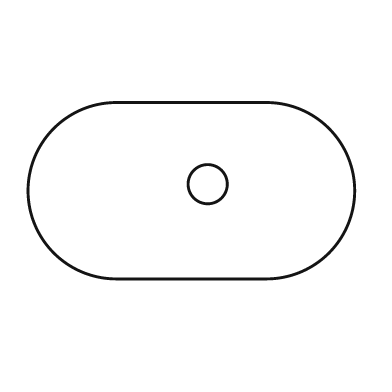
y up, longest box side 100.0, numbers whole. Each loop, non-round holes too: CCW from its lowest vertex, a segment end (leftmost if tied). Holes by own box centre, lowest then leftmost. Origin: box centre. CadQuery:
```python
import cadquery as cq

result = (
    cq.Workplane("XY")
    .moveTo(-23.0, -27.0)
    .lineTo(23.0, -27.0)
    .threePointArc((50.0, 0.0), (23.0, 27.0))
    .lineTo(-23.0, 27.0)
    .threePointArc((-50.0, 0.0), (-23.0, -27.0))
    .close()
    .moveTo(5.0, 2.0)
    .circle(6.0)
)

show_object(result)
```